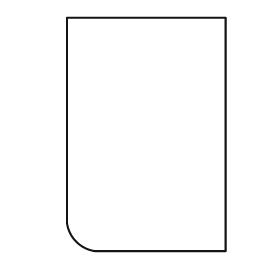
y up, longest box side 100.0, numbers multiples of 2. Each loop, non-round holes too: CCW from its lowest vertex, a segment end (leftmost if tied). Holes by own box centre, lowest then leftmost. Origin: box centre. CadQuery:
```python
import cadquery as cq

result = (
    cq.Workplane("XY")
    .moveTo(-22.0, -50.0)
    .lineTo(34.0, -50.0)
    .lineTo(34.0, 50.0)
    .lineTo(-34.0, 50.0)
    .lineTo(-34.0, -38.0)
    .threePointArc((-30.0, -46.0), (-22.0, -50.0))
    .close()
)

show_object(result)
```